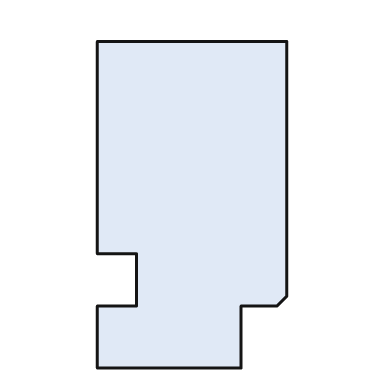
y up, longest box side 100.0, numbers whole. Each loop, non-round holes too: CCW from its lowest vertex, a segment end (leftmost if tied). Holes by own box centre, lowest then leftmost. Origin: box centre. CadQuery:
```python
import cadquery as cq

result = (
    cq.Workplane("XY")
    .moveTo(-29.0, -50.0)
    .lineTo(15.0, -50.0)
    .lineTo(15.0, -31.0)
    .lineTo(26.0, -31.0)
    .lineTo(29.0, -28.0)
    .lineTo(29.0, 50.0)
    .lineTo(-29.0, 50.0)
    .lineTo(-29.0, -15.0)
    .lineTo(-17.0, -15.0)
    .lineTo(-17.0, -31.0)
    .lineTo(-29.0, -31.0)
    .close()
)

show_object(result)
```